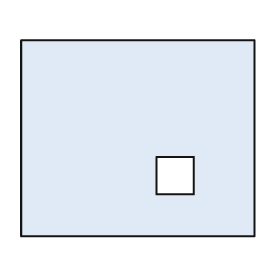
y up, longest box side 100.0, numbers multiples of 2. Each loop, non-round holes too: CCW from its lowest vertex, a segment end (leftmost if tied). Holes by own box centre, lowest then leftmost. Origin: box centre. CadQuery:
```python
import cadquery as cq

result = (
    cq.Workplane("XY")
    .moveTo(-50.0, -42.0)
    .lineTo(50.0, -42.0)
    .lineTo(50.0, 42.0)
    .lineTo(-50.0, 42.0)
    .close()
    .moveTo(8.0, -24.0)
    .lineTo(24.0, -24.0)
    .lineTo(24.0, -8.0)
    .lineTo(8.0, -8.0)
    .close()
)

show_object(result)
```